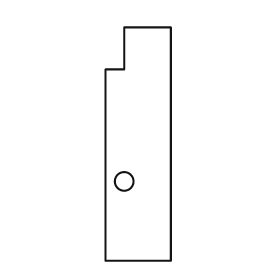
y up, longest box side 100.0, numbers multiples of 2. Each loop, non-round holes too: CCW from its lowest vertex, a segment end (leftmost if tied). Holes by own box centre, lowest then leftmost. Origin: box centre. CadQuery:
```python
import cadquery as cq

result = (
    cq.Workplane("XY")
    .moveTo(-14.0, -50.0)
    .lineTo(14.0, -50.0)
    .lineTo(14.0, 50.0)
    .lineTo(-6.0, 50.0)
    .lineTo(-6.0, 32.0)
    .lineTo(-14.0, 32.0)
    .close()
    .moveTo(-6.0, -16.0)
    .circle(4.0)
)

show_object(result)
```